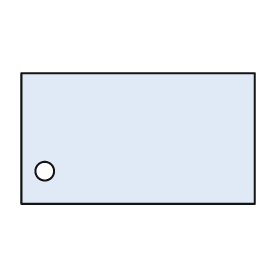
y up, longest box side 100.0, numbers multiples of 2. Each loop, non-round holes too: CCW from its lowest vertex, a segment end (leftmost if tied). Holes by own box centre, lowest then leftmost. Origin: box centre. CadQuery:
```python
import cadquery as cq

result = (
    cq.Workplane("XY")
    .moveTo(-50.0, -28.0)
    .lineTo(50.0, -28.0)
    .lineTo(50.0, 28.0)
    .lineTo(-50.0, 28.0)
    .close()
    .moveTo(-40.0, -14.0)
    .circle(4.0)
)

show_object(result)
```